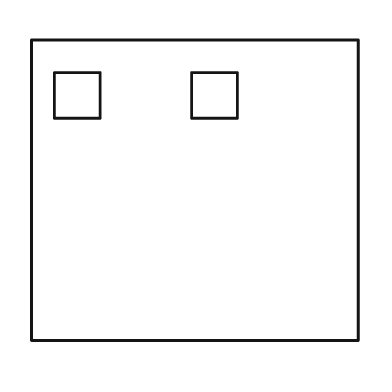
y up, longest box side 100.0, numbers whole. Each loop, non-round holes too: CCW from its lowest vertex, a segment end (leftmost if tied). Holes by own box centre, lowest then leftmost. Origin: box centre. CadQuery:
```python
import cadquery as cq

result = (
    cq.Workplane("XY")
    .moveTo(-50.0, -46.0)
    .lineTo(50.0, -46.0)
    .lineTo(50.0, 46.0)
    .lineTo(-50.0, 46.0)
    .close()
    .moveTo(-43.0, 22.0)
    .lineTo(-29.0, 22.0)
    .lineTo(-29.0, 36.0)
    .lineTo(-43.0, 36.0)
    .close()
    .moveTo(-1.0, 22.0)
    .lineTo(13.0, 22.0)
    .lineTo(13.0, 36.0)
    .lineTo(-1.0, 36.0)
    .close()
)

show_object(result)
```